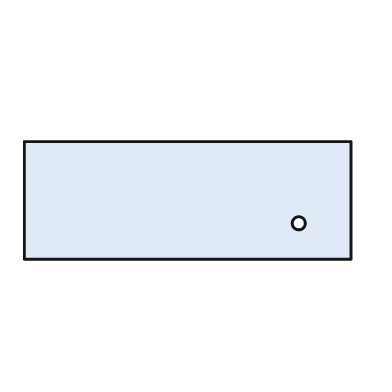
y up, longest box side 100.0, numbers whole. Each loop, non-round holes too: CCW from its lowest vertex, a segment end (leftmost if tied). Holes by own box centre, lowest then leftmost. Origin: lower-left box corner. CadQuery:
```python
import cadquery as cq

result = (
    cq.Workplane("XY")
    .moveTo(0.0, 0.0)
    .lineTo(100.0, 0.0)
    .lineTo(100.0, 36.0)
    .lineTo(0.0, 36.0)
    .close()
    .moveTo(84.0, 11.0)
    .circle(2.0)
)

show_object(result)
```